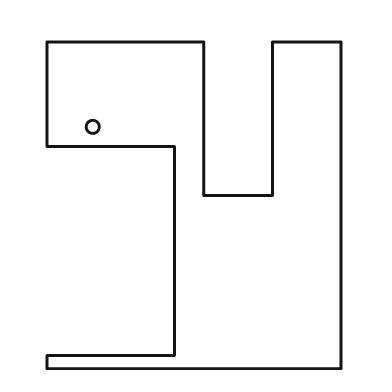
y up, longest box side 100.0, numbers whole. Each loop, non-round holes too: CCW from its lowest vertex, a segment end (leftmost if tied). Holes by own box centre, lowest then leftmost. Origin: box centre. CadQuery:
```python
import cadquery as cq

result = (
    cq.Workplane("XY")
    .moveTo(-45.0, -50.0)
    .lineTo(45.0, -50.0)
    .lineTo(45.0, 50.0)
    .lineTo(24.0, 50.0)
    .lineTo(24.0, 3.0)
    .lineTo(3.0, 3.0)
    .lineTo(3.0, 50.0)
    .lineTo(-45.0, 50.0)
    .lineTo(-45.0, 18.0)
    .lineTo(-6.0, 18.0)
    .lineTo(-6.0, -46.0)
    .lineTo(-45.0, -46.0)
    .close()
    .moveTo(-31.0, 24.0)
    .circle(2.0)
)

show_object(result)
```